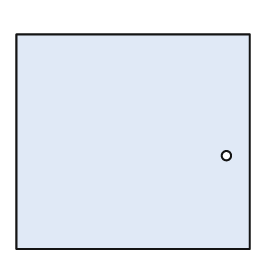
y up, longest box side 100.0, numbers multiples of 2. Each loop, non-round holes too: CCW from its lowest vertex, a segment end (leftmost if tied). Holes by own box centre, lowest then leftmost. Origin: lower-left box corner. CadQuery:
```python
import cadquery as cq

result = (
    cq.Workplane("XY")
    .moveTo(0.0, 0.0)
    .lineTo(100.0, 0.0)
    .lineTo(100.0, 92.0)
    .lineTo(0.0, 92.0)
    .close()
    .moveTo(90.0, 40.0)
    .circle(2.0)
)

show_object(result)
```